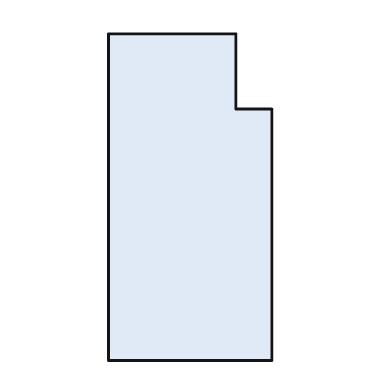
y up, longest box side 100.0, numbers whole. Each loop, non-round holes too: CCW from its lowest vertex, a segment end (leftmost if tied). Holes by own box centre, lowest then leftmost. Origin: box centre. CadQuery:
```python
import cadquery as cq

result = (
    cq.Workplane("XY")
    .moveTo(-25.0, -50.0)
    .lineTo(25.0, -50.0)
    .lineTo(25.0, 27.0)
    .lineTo(14.0, 27.0)
    .lineTo(14.0, 50.0)
    .lineTo(-25.0, 50.0)
    .close()
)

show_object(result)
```